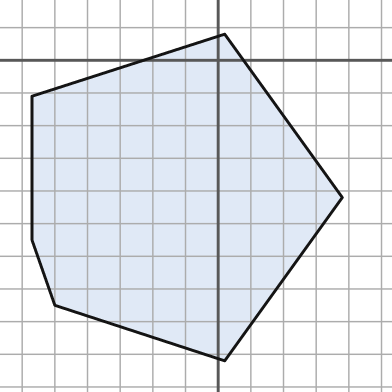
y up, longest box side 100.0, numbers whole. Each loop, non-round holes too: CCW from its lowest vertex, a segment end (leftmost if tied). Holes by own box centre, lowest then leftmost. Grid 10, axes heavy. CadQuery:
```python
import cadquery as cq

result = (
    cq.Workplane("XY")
    .moveTo(2.0, -92.0)
    .lineTo(38.0, -42.0)
    .lineTo(2.0, 8.0)
    .lineTo(-57.0, -11.0)
    .lineTo(-57.0, -55.0)
    .lineTo(-50.0, -75.0)
    .close()
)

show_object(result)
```